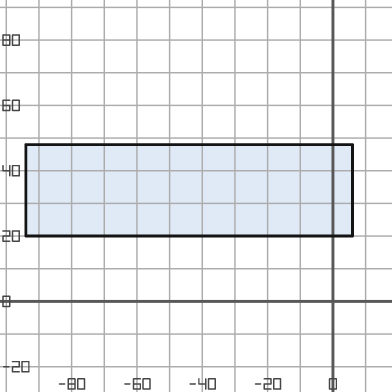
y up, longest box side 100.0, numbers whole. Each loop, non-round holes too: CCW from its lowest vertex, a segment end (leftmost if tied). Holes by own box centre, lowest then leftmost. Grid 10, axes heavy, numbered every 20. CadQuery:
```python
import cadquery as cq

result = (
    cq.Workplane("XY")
    .moveTo(-94.0, 20.0)
    .lineTo(6.0, 20.0)
    .lineTo(6.0, 48.0)
    .lineTo(-94.0, 48.0)
    .close()
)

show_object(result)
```